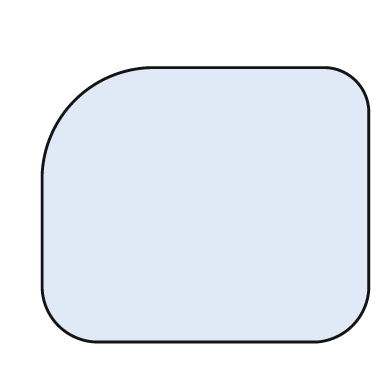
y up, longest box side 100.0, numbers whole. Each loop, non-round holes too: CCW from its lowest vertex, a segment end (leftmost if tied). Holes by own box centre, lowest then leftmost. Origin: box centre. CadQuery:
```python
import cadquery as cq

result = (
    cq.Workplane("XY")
    .moveTo(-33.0, -42.0)
    .lineTo(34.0, -42.0)
    .threePointArc((45.0, -37.0), (50.0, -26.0))
    .lineTo(50.0, 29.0)
    .threePointArc((46.0, 38.0), (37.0, 42.0))
    .lineTo(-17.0, 42.0)
    .threePointArc((-40.0, 32.0), (-50.0, 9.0))
    .lineTo(-50.0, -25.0)
    .threePointArc((-45.0, -37.0), (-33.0, -42.0))
    .close()
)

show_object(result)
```